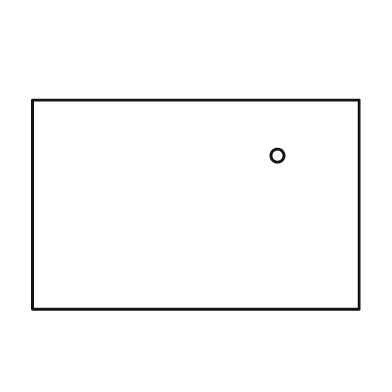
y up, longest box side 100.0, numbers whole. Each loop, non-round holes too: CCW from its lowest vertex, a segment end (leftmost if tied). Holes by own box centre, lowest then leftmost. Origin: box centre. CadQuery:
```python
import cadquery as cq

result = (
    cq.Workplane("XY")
    .moveTo(-50.0, -32.0)
    .lineTo(50.0, -32.0)
    .lineTo(50.0, 32.0)
    .lineTo(-50.0, 32.0)
    .close()
    .moveTo(25.0, 15.0)
    .circle(2.0)
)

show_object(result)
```